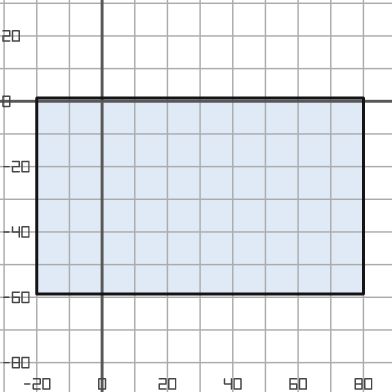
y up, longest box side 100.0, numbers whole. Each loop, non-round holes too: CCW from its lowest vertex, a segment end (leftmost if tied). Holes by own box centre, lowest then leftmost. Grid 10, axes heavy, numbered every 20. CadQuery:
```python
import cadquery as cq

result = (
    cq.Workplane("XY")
    .moveTo(-20.0, -59.0)
    .lineTo(80.0, -59.0)
    .lineTo(80.0, 1.0)
    .lineTo(-20.0, 1.0)
    .close()
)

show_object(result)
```